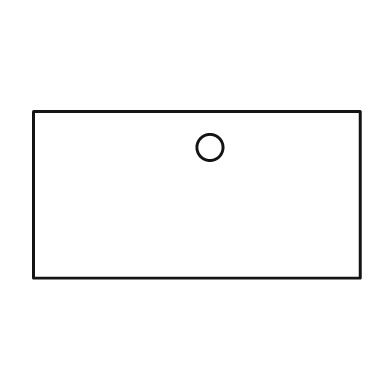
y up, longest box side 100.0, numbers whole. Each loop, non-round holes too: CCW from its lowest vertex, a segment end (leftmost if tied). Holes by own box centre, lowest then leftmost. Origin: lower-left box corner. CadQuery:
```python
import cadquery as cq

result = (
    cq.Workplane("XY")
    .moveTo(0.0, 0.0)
    .lineTo(100.0, 0.0)
    .lineTo(100.0, 51.0)
    .lineTo(0.0, 51.0)
    .close()
    .moveTo(54.0, 40.0)
    .circle(4.0)
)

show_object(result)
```